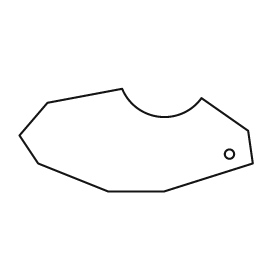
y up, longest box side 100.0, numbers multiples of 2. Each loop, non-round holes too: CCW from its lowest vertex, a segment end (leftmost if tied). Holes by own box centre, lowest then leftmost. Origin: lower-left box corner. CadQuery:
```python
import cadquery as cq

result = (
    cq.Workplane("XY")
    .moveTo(38.0, 0.0)
    .lineTo(62.0, 0.0)
    .lineTo(100.0, 12.0)
    .lineTo(98.0, 26.0)
    .lineTo(78.0, 40.0)
    .threePointArc((60.0, 32.0), (44.0, 44.0))
    .lineTo(12.0, 38.0)
    .lineTo(0.0, 24.0)
    .lineTo(8.0, 12.0)
    .close()
    .moveTo(90.0, 16.0)
    .circle(2.0)
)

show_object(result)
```